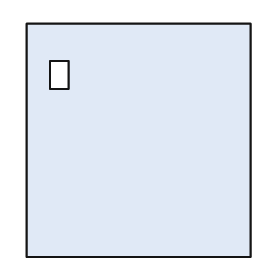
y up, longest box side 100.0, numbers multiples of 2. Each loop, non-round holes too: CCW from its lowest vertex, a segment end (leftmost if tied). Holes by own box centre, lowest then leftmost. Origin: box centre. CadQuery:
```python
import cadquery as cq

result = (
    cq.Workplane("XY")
    .moveTo(-48.0, -50.0)
    .lineTo(48.0, -50.0)
    .lineTo(48.0, 50.0)
    .lineTo(-48.0, 50.0)
    .close()
    .moveTo(-38.0, 22.0)
    .lineTo(-30.0, 22.0)
    .lineTo(-30.0, 34.0)
    .lineTo(-38.0, 34.0)
    .close()
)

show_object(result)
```